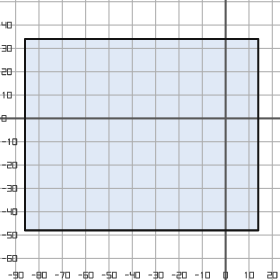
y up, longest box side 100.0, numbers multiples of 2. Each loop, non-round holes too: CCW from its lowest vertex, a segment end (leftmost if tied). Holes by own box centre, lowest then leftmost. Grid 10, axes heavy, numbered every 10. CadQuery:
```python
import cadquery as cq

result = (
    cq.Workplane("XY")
    .moveTo(-86.0, -48.0)
    .lineTo(14.0, -48.0)
    .lineTo(14.0, 34.0)
    .lineTo(-86.0, 34.0)
    .close()
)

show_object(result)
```